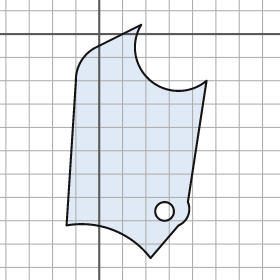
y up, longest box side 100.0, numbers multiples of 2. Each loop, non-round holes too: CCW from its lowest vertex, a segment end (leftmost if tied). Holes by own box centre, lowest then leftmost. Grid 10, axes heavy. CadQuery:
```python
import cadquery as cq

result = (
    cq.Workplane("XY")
    .moveTo(22.0, -96.0)
    .lineTo(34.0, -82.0)
    .threePointArc((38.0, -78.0), (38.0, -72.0))
    .lineTo(46.0, -20.0)
    .threePointArc((22.0, -20.0), (18.0, 4.0))
    .lineTo(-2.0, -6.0)
    .threePointArc((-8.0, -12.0), (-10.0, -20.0))
    .lineTo(-14.0, -82.0)
    .threePointArc((6.0, -84.0), (22.0, -96.0))
    .close()
    .moveTo(28.0, -76.0)
    .circle(4.0)
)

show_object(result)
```